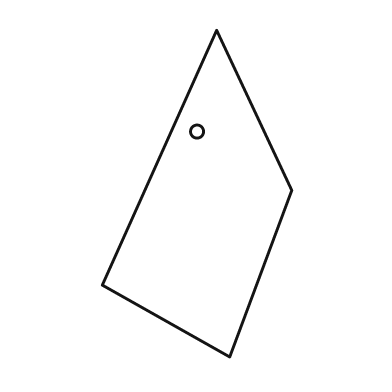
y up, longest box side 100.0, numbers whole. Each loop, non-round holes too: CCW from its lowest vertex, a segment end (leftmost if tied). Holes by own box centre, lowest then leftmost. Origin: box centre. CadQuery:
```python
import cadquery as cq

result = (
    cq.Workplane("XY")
    .moveTo(10.0, -50.0)
    .lineTo(29.0, 1.0)
    .lineTo(6.0, 50.0)
    .lineTo(-29.0, -28.0)
    .close()
    .moveTo(0.0, 19.0)
    .circle(2.0)
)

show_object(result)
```